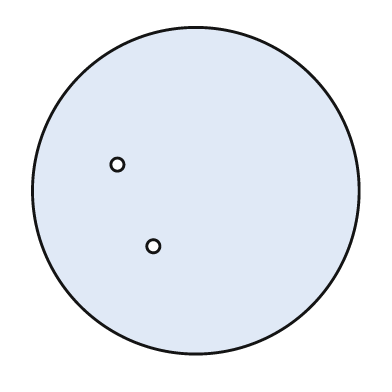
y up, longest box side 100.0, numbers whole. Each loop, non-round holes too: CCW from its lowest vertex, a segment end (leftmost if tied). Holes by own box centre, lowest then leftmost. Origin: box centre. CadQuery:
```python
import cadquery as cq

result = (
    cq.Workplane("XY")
    .moveTo(0.0, 0.0)
    .circle(50.0)
    .moveTo(-13.0, -17.0)
    .circle(2.0)
    .moveTo(-24.0, 8.0)
    .circle(2.0)
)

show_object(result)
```